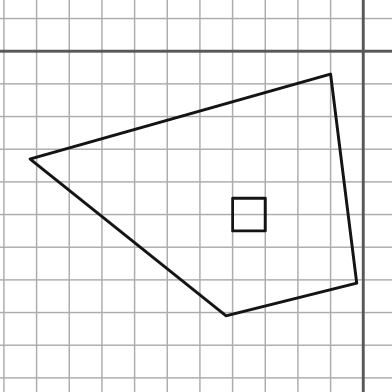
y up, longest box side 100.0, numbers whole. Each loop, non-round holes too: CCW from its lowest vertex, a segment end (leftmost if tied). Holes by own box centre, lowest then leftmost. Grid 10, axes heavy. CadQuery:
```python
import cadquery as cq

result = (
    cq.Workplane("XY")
    .moveTo(-42.0, -81.0)
    .lineTo(-2.0, -71.0)
    .lineTo(-10.0, -7.0)
    .lineTo(-102.0, -33.0)
    .close()
    .moveTo(-40.0, -55.0)
    .lineTo(-30.0, -55.0)
    .lineTo(-30.0, -45.0)
    .lineTo(-40.0, -45.0)
    .close()
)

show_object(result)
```